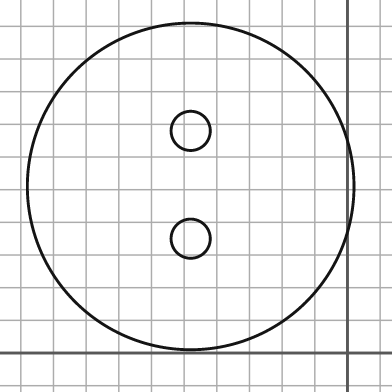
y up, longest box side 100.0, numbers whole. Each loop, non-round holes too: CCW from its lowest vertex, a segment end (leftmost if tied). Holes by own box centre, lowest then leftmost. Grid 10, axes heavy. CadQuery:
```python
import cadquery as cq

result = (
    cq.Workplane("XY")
    .moveTo(-48.0, 51.0)
    .circle(50.0)
    .moveTo(-48.0, 35.0)
    .circle(6.0)
    .moveTo(-48.0, 68.0)
    .circle(6.0)
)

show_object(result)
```